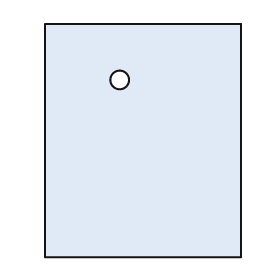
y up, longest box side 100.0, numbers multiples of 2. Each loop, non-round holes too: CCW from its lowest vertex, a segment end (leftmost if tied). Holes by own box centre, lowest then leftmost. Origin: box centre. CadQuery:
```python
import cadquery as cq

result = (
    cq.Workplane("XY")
    .moveTo(-42.0, -50.0)
    .lineTo(42.0, -50.0)
    .lineTo(42.0, 50.0)
    .lineTo(-42.0, 50.0)
    .close()
    .moveTo(-10.0, 26.0)
    .circle(4.0)
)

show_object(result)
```